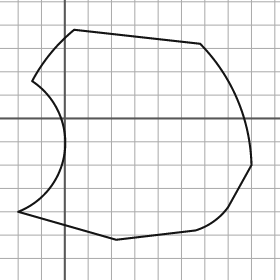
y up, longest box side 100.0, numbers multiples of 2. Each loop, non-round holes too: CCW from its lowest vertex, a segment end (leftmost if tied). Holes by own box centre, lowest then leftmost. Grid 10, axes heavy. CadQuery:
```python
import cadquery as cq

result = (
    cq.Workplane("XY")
    .moveTo(22.0, -52.0)
    .lineTo(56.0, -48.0)
    .threePointArc((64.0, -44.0), (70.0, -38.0))
    .lineTo(80.0, -20.0)
    .threePointArc((74.0, 8.0), (58.0, 32.0))
    .lineTo(4.0, 38.0)
    .threePointArc((-6.0, 28.0), (-14.0, 16.0))
    .threePointArc((0.0, -14.0), (-20.0, -40.0))
    .close()
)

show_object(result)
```